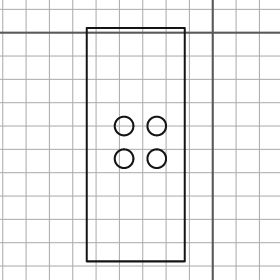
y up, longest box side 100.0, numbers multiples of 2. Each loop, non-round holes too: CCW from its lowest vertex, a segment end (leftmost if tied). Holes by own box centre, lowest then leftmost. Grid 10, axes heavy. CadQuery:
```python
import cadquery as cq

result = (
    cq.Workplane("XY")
    .moveTo(-54.0, -98.0)
    .lineTo(-12.0, -98.0)
    .lineTo(-12.0, 2.0)
    .lineTo(-54.0, 2.0)
    .close()
    .moveTo(-38.0, -54.0)
    .circle(4.0)
    .moveTo(-24.0, -54.0)
    .circle(4.0)
    .moveTo(-38.0, -40.0)
    .circle(4.0)
    .moveTo(-24.0, -40.0)
    .circle(4.0)
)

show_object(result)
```